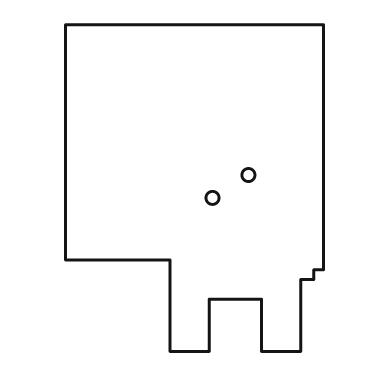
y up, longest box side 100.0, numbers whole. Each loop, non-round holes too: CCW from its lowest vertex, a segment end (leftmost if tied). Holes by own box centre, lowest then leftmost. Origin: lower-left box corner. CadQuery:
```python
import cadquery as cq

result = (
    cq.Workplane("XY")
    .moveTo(32.0, 0.0)
    .lineTo(44.0, 0.0)
    .lineTo(44.0, 16.0)
    .lineTo(60.0, 16.0)
    .lineTo(60.0, 0.0)
    .lineTo(72.0, 0.0)
    .lineTo(72.0, 22.0)
    .lineTo(76.0, 22.0)
    .lineTo(76.0, 25.0)
    .lineTo(79.0, 25.0)
    .lineTo(79.0, 100.0)
    .lineTo(0.0, 100.0)
    .lineTo(0.0, 28.0)
    .lineTo(32.0, 28.0)
    .close()
    .moveTo(45.0, 47.0)
    .circle(2.0)
    .moveTo(56.0, 54.0)
    .circle(2.0)
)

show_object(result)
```